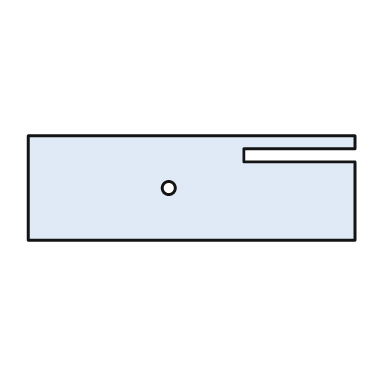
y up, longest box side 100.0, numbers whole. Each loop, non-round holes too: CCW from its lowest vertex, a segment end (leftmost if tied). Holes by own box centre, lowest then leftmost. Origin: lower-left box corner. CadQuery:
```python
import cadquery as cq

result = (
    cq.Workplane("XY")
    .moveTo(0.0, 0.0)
    .lineTo(100.0, 0.0)
    .lineTo(100.0, 24.0)
    .lineTo(66.0, 24.0)
    .lineTo(66.0, 28.0)
    .lineTo(100.0, 28.0)
    .lineTo(100.0, 32.0)
    .lineTo(0.0, 32.0)
    .close()
    .moveTo(43.0, 16.0)
    .circle(2.0)
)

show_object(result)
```